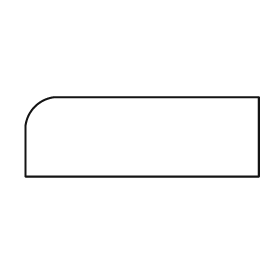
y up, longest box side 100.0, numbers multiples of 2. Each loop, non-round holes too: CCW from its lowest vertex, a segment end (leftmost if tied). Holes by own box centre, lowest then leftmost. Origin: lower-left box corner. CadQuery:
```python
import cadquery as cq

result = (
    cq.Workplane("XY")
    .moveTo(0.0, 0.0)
    .lineTo(100.0, 0.0)
    .lineTo(100.0, 34.0)
    .lineTo(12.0, 34.0)
    .threePointArc((4.0, 30.0), (0.0, 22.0))
    .close()
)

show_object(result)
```